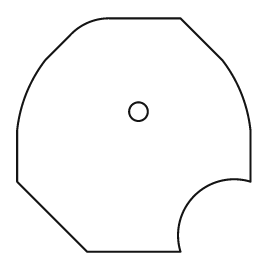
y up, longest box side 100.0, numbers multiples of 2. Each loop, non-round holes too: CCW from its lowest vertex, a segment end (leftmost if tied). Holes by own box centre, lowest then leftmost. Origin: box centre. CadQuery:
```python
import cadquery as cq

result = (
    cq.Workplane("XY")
    .moveTo(-20.0, -50.0)
    .lineTo(20.0, -50.0)
    .threePointArc((26.0, -26.0), (50.0, -20.0))
    .lineTo(50.0, 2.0)
    .threePointArc((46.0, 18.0), (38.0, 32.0))
    .lineTo(20.0, 50.0)
    .lineTo(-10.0, 50.0)
    .threePointArc((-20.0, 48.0), (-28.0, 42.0))
    .lineTo(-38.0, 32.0)
    .threePointArc((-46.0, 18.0), (-50.0, 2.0))
    .lineTo(-50.0, -20.0)
    .close()
    .moveTo(2.0, 10.0)
    .circle(4.0)
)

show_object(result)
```